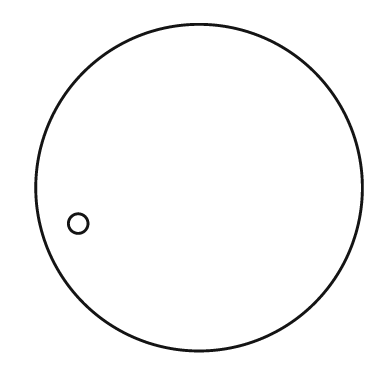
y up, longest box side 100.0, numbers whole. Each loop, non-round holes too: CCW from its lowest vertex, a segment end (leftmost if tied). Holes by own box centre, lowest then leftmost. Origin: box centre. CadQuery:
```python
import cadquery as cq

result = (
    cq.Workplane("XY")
    .moveTo(0.0, 0.0)
    .circle(50.0)
    .moveTo(-37.0, -11.0)
    .circle(3.0)
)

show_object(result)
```